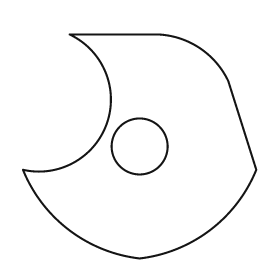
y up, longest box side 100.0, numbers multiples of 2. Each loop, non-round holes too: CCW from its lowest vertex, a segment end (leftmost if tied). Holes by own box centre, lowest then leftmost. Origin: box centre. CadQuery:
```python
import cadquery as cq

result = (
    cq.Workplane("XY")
    .moveTo(0.0, -48.0)
    .threePointArc((30.0, -36.0), (50.0, -10.0))
    .lineTo(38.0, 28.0)
    .threePointArc((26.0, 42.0), (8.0, 48.0))
    .lineTo(-30.0, 48.0)
    .threePointArc((-14.0, 10.0), (-50.0, -10.0))
    .threePointArc((-30.0, -36.0), (0.0, -48.0))
    .close()
    .moveTo(0.0, 0.0)
    .circle(12.0)
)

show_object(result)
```